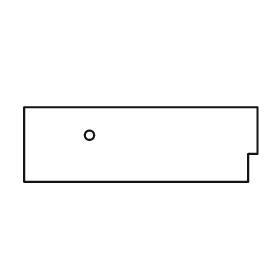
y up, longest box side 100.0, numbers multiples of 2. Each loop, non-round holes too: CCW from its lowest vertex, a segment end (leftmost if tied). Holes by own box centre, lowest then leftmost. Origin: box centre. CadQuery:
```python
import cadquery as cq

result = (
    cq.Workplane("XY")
    .moveTo(-50.0, -16.0)
    .lineTo(46.0, -16.0)
    .lineTo(46.0, -4.0)
    .lineTo(50.0, -4.0)
    .lineTo(50.0, 16.0)
    .lineTo(-50.0, 16.0)
    .close()
    .moveTo(-22.0, 4.0)
    .circle(2.0)
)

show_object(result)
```